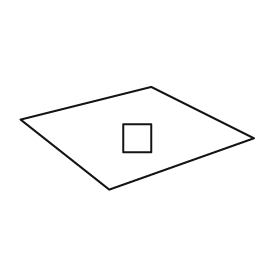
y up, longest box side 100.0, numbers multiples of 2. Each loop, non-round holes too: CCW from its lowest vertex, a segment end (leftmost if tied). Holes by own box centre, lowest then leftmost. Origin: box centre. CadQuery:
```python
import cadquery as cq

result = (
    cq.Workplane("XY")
    .moveTo(-12.0, -22.0)
    .lineTo(50.0, 0.0)
    .lineTo(6.0, 22.0)
    .lineTo(-50.0, 8.0)
    .close()
    .moveTo(-6.0, -6.0)
    .lineTo(6.0, -6.0)
    .lineTo(6.0, 6.0)
    .lineTo(-6.0, 6.0)
    .close()
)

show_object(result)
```